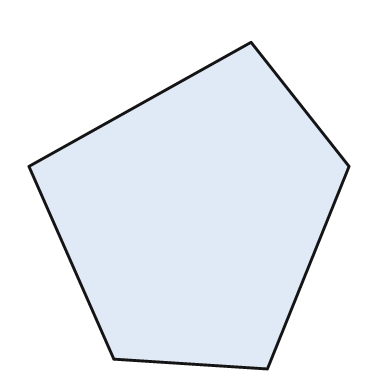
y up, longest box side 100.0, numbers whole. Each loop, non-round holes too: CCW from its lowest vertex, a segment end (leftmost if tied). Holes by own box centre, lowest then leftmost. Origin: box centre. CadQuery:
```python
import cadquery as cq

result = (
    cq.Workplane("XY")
    .moveTo(24.0, -50.0)
    .lineTo(49.0, 12.0)
    .lineTo(19.0, 50.0)
    .lineTo(-49.0, 12.0)
    .lineTo(-23.0, -47.0)
    .close()
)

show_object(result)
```